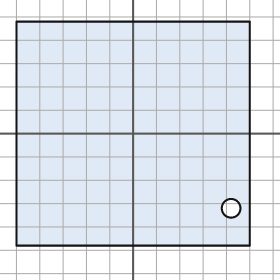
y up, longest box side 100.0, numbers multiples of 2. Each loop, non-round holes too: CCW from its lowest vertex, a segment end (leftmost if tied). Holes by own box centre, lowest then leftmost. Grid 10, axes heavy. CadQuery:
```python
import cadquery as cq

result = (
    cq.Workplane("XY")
    .moveTo(-50.0, -48.0)
    .lineTo(50.0, -48.0)
    .lineTo(50.0, 48.0)
    .lineTo(-50.0, 48.0)
    .close()
    .moveTo(42.0, -32.0)
    .circle(4.0)
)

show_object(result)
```